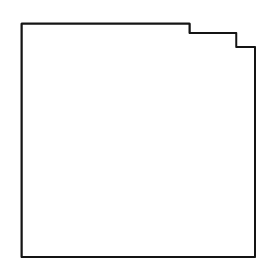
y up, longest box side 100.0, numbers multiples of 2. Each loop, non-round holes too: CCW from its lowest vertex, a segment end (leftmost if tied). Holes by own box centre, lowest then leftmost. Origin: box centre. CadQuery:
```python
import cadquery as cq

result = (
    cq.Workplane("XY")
    .moveTo(-50.0, -50.0)
    .lineTo(50.0, -50.0)
    .lineTo(50.0, 40.0)
    .lineTo(42.0, 40.0)
    .lineTo(42.0, 46.0)
    .lineTo(22.0, 46.0)
    .lineTo(22.0, 50.0)
    .lineTo(-50.0, 50.0)
    .close()
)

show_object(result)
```